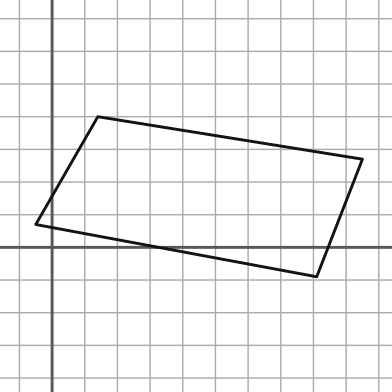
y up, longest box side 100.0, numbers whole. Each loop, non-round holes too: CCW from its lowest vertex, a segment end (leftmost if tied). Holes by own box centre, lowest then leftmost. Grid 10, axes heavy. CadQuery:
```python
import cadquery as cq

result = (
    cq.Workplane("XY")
    .moveTo(81.0, -9.0)
    .lineTo(95.0, 27.0)
    .lineTo(14.0, 40.0)
    .lineTo(-5.0, 7.0)
    .close()
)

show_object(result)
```